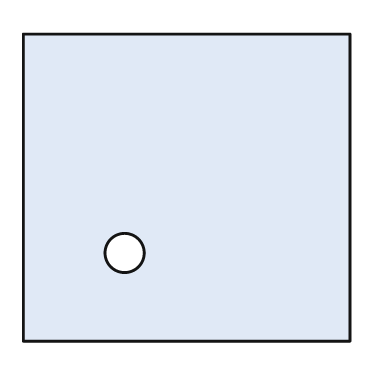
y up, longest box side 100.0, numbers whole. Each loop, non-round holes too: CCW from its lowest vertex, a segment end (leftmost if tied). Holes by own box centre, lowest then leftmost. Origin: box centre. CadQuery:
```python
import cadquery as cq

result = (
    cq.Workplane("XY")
    .moveTo(-50.0, -47.0)
    .lineTo(50.0, -47.0)
    .lineTo(50.0, 47.0)
    .lineTo(-50.0, 47.0)
    .close()
    .moveTo(-19.0, -20.0)
    .circle(6.0)
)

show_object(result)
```